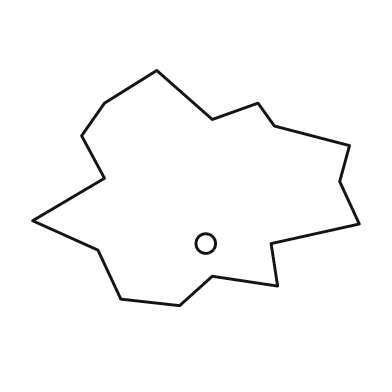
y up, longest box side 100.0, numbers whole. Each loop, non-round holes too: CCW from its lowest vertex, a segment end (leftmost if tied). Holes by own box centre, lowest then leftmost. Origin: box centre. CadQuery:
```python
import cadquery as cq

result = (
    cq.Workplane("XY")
    .moveTo(-5.0, -36.0)
    .lineTo(5.0, -27.0)
    .lineTo(25.0, -30.0)
    .lineTo(23.0, -17.0)
    .lineTo(50.0, -11.0)
    .lineTo(44.0, 2.0)
    .lineTo(47.0, 13.0)
    .lineTo(24.0, 19.0)
    .lineTo(19.0, 26.0)
    .lineTo(5.0, 21.0)
    .lineTo(-12.0, 36.0)
    .lineTo(-28.0, 26.0)
    .lineTo(-35.0, 16.0)
    .lineTo(-28.0, 3.0)
    .lineTo(-50.0, -10.0)
    .lineTo(-30.0, -19.0)
    .lineTo(-23.0, -34.0)
    .close()
    .moveTo(3.0, -17.0)
    .circle(3.0)
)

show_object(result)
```